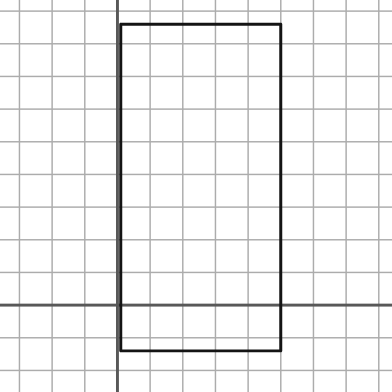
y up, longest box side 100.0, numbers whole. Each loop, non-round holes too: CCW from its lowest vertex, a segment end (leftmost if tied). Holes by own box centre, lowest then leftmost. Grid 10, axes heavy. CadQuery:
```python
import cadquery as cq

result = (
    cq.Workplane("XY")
    .moveTo(1.0, -14.0)
    .lineTo(50.0, -14.0)
    .lineTo(50.0, 86.0)
    .lineTo(1.0, 86.0)
    .close()
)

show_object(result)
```